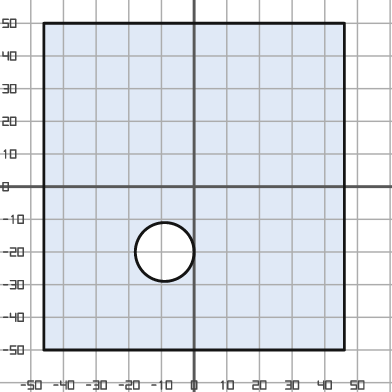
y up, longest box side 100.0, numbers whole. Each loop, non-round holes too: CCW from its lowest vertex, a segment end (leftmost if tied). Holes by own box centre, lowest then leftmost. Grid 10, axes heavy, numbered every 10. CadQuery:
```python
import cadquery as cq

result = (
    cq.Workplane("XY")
    .moveTo(-46.0, -50.0)
    .lineTo(46.0, -50.0)
    .lineTo(46.0, 50.0)
    .lineTo(-46.0, 50.0)
    .close()
    .moveTo(-9.0, -20.0)
    .circle(9.0)
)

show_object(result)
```